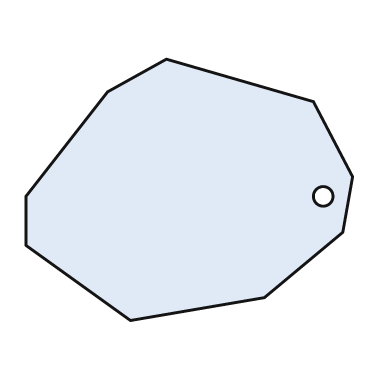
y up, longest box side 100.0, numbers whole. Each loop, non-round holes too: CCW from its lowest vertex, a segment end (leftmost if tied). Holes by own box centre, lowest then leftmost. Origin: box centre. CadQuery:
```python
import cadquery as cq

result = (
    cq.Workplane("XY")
    .moveTo(-18.0, -40.0)
    .lineTo(23.0, -33.0)
    .lineTo(47.0, -13.0)
    .lineTo(50.0, 4.0)
    .lineTo(38.0, 27.0)
    .lineTo(-7.0, 40.0)
    .lineTo(-25.0, 30.0)
    .lineTo(-50.0, -2.0)
    .lineTo(-50.0, -17.0)
    .close()
    .moveTo(41.0, -2.0)
    .circle(3.0)
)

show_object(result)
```